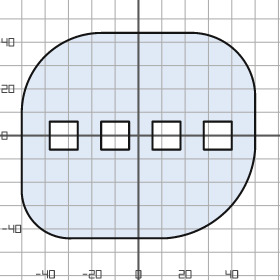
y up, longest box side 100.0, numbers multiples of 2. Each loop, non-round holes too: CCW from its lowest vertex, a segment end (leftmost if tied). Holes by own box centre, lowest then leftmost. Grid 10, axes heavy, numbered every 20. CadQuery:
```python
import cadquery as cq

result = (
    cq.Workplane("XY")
    .moveTo(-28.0, -44.0)
    .lineTo(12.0, -44.0)
    .threePointArc((38.0, -32.0), (50.0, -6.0))
    .lineTo(50.0, 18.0)
    .threePointArc((42.0, 36.0), (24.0, 44.0))
    .lineTo(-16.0, 44.0)
    .threePointArc((-40.0, 34.0), (-50.0, 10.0))
    .lineTo(-50.0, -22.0)
    .threePointArc((-44.0, -38.0), (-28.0, -44.0))
    .close()
    .moveTo(-38.0, -6.0)
    .lineTo(-26.0, -6.0)
    .lineTo(-26.0, 6.0)
    .lineTo(-38.0, 6.0)
    .close()
    .moveTo(-16.0, -6.0)
    .lineTo(-4.0, -6.0)
    .lineTo(-4.0, 6.0)
    .lineTo(-16.0, 6.0)
    .close()
    .moveTo(6.0, -6.0)
    .lineTo(18.0, -6.0)
    .lineTo(18.0, 6.0)
    .lineTo(6.0, 6.0)
    .close()
    .moveTo(28.0, -6.0)
    .lineTo(40.0, -6.0)
    .lineTo(40.0, 6.0)
    .lineTo(28.0, 6.0)
    .close()
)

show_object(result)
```